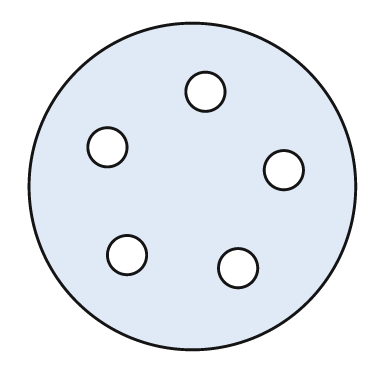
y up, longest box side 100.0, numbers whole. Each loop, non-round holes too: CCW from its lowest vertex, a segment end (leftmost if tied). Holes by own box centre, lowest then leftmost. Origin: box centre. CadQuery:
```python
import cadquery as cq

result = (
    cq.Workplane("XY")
    .moveTo(0.0, 0.0)
    .circle(50.0)
    .moveTo(14.0, -25.0)
    .circle(6.0)
    .moveTo(-20.0, -21.0)
    .circle(6.0)
    .moveTo(28.0, 5.0)
    .circle(6.0)
    .moveTo(-26.0, 12.0)
    .circle(6.0)
    .moveTo(4.0, 29.0)
    .circle(6.0)
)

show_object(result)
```